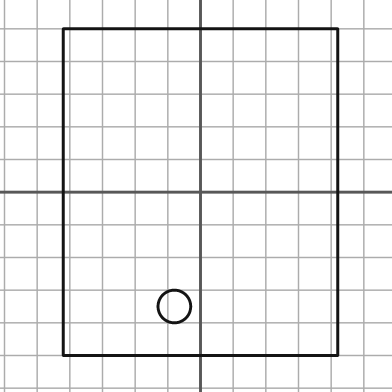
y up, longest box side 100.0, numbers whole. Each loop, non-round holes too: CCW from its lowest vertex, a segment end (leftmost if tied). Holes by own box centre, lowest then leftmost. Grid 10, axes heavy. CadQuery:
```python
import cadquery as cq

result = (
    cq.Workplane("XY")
    .moveTo(-42.0, -50.0)
    .lineTo(42.0, -50.0)
    .lineTo(42.0, 50.0)
    .lineTo(-42.0, 50.0)
    .close()
    .moveTo(-8.0, -35.0)
    .circle(5.0)
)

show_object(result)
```